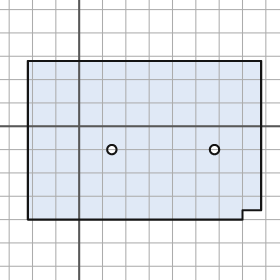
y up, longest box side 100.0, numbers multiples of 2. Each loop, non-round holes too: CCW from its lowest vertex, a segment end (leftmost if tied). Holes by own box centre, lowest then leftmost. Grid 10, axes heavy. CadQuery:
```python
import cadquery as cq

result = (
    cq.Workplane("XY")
    .moveTo(-22.0, -40.0)
    .lineTo(70.0, -40.0)
    .lineTo(70.0, -36.0)
    .lineTo(78.0, -36.0)
    .lineTo(78.0, 28.0)
    .lineTo(-22.0, 28.0)
    .close()
    .moveTo(14.0, -10.0)
    .circle(2.0)
    .moveTo(58.0, -10.0)
    .circle(2.0)
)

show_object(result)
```